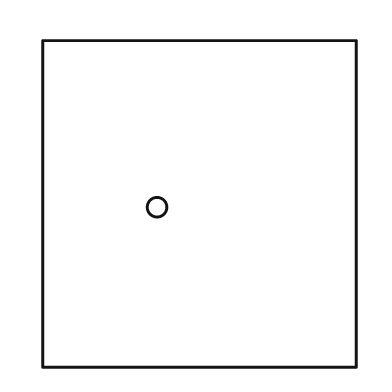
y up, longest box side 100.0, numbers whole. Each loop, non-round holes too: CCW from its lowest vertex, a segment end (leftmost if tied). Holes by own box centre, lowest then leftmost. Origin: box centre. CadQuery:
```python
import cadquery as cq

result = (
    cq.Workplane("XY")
    .moveTo(-48.0, -50.0)
    .lineTo(48.0, -50.0)
    .lineTo(48.0, 50.0)
    .lineTo(-48.0, 50.0)
    .close()
    .moveTo(-13.0, -1.0)
    .circle(3.0)
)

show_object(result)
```